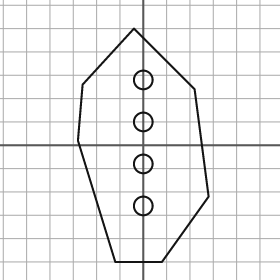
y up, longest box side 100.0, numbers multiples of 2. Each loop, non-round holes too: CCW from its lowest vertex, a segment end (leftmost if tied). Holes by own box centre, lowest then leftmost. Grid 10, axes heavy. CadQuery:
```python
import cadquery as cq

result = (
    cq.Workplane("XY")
    .moveTo(-12.0, -50.0)
    .lineTo(8.0, -50.0)
    .lineTo(28.0, -22.0)
    .lineTo(22.0, 24.0)
    .lineTo(-4.0, 50.0)
    .lineTo(-26.0, 26.0)
    .lineTo(-28.0, 2.0)
    .close()
    .moveTo(0.0, -26.0)
    .circle(4.0)
    .moveTo(0.0, -8.0)
    .circle(4.0)
    .moveTo(0.0, 10.0)
    .circle(4.0)
    .moveTo(0.0, 28.0)
    .circle(4.0)
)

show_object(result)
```